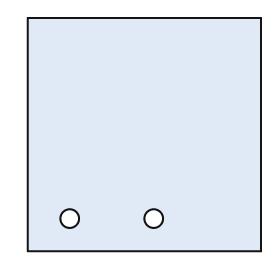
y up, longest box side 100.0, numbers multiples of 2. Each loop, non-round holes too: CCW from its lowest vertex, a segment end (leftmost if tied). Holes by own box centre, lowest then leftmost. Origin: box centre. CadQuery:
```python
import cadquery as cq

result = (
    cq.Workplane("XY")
    .moveTo(-50.0, -50.0)
    .lineTo(50.0, -50.0)
    .lineTo(50.0, 50.0)
    .lineTo(-50.0, 50.0)
    .close()
    .moveTo(-32.0, -36.0)
    .circle(4.0)
    .moveTo(4.0, -36.0)
    .circle(4.0)
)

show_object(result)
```